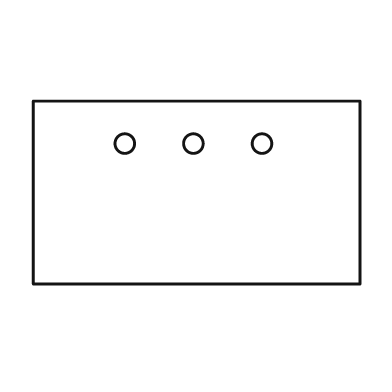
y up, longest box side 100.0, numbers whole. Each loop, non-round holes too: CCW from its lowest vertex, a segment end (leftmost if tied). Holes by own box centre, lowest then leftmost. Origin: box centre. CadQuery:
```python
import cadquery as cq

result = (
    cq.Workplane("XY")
    .moveTo(-50.0, -28.0)
    .lineTo(50.0, -28.0)
    .lineTo(50.0, 28.0)
    .lineTo(-50.0, 28.0)
    .close()
    .moveTo(-22.0, 15.0)
    .circle(3.0)
    .moveTo(-1.0, 15.0)
    .circle(3.0)
    .moveTo(20.0, 15.0)
    .circle(3.0)
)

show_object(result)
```